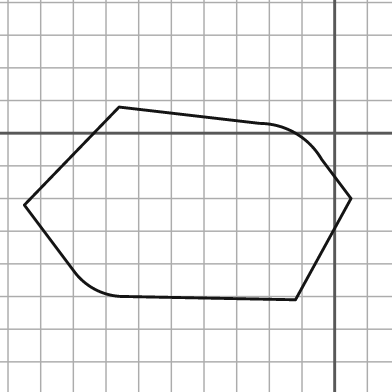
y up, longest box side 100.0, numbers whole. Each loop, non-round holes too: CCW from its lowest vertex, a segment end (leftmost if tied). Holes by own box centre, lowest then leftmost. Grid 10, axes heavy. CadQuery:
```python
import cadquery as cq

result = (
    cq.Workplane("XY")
    .moveTo(-12.0, -51.0)
    .lineTo(5.0, -20.0)
    .lineTo(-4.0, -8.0)
    .threePointArc((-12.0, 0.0), (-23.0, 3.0))
    .lineTo(-66.0, 8.0)
    .lineTo(-95.0, -22.0)
    .lineTo(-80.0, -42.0)
    .threePointArc((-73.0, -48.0), (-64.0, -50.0))
    .close()
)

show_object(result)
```